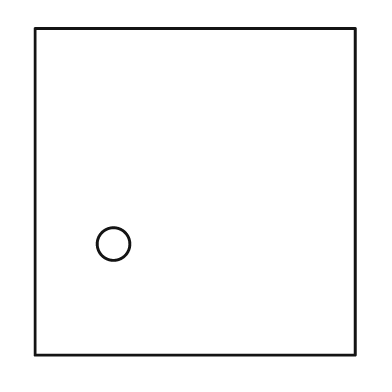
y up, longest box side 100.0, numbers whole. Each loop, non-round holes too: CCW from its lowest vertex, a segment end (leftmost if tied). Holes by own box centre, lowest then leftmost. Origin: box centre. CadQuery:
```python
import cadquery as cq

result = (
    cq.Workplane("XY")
    .moveTo(-49.0, -50.0)
    .lineTo(49.0, -50.0)
    .lineTo(49.0, 50.0)
    .lineTo(-49.0, 50.0)
    .close()
    .moveTo(-25.0, -16.0)
    .circle(5.0)
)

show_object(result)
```